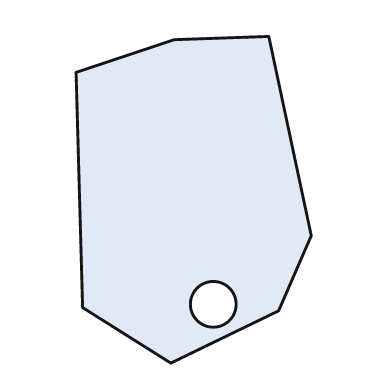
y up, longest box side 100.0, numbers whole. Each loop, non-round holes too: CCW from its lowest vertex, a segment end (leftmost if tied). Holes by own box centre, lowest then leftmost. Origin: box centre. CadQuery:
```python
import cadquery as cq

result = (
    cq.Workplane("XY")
    .moveTo(-7.0, -50.0)
    .lineTo(26.0, -34.0)
    .lineTo(36.0, -11.0)
    .lineTo(23.0, 50.0)
    .lineTo(-6.0, 49.0)
    .lineTo(-36.0, 39.0)
    .lineTo(-34.0, -33.0)
    .close()
    .moveTo(6.0, -32.0)
    .circle(7.0)
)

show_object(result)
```